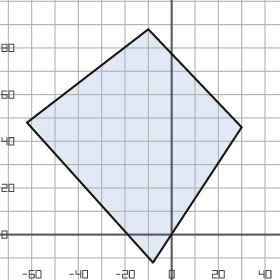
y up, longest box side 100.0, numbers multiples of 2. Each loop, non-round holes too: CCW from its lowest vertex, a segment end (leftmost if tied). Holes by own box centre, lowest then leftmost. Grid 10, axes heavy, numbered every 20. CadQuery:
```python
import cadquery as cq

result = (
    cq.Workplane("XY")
    .moveTo(-8.0, -12.0)
    .lineTo(30.0, 46.0)
    .lineTo(-10.0, 88.0)
    .lineTo(-62.0, 48.0)
    .close()
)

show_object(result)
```